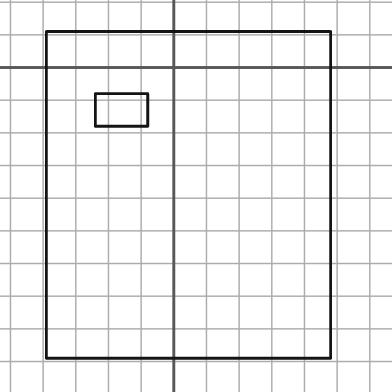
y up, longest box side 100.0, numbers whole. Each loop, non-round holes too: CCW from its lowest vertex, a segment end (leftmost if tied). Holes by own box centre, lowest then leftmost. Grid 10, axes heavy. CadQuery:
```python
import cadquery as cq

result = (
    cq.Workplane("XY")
    .moveTo(-39.0, -89.0)
    .lineTo(48.0, -89.0)
    .lineTo(48.0, 11.0)
    .lineTo(-39.0, 11.0)
    .close()
    .moveTo(-24.0, -18.0)
    .lineTo(-8.0, -18.0)
    .lineTo(-8.0, -8.0)
    .lineTo(-24.0, -8.0)
    .close()
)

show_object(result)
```